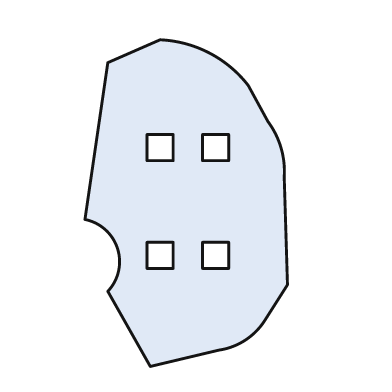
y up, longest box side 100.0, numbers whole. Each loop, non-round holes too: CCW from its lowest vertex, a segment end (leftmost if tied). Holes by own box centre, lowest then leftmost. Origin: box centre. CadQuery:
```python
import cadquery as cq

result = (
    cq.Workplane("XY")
    .moveTo(-11.0, -50.0)
    .lineTo(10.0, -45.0)
    .threePointArc((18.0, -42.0), (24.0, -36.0))
    .lineTo(31.0, -25.0)
    .lineTo(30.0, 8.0)
    .threePointArc((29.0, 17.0), (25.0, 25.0))
    .lineTo(19.0, 36.0)
    .threePointArc((7.0, 46.0), (-8.0, 50.0))
    .lineTo(-24.0, 43.0)
    .lineTo(-31.0, -5.0)
    .threePointArc((-21.0, -14.0), (-24.0, -27.0))
    .close()
    .moveTo(-12.0, -20.0)
    .lineTo(-4.0, -20.0)
    .lineTo(-4.0, -12.0)
    .lineTo(-12.0, -12.0)
    .close()
    .moveTo(5.0, -20.0)
    .lineTo(13.0, -20.0)
    .lineTo(13.0, -12.0)
    .lineTo(5.0, -12.0)
    .close()
    .moveTo(-12.0, 13.0)
    .lineTo(-4.0, 13.0)
    .lineTo(-4.0, 21.0)
    .lineTo(-12.0, 21.0)
    .close()
    .moveTo(5.0, 13.0)
    .lineTo(13.0, 13.0)
    .lineTo(13.0, 21.0)
    .lineTo(5.0, 21.0)
    .close()
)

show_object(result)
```